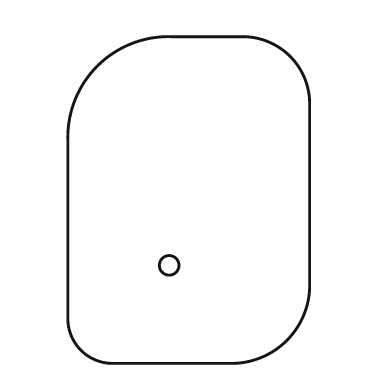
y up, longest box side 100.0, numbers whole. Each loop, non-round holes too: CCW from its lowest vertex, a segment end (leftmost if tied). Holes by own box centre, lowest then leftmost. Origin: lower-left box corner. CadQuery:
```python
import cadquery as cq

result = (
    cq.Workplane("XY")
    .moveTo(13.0, 0.0)
    .lineTo(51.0, 0.0)
    .threePointArc((67.0, 7.0), (74.0, 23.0))
    .lineTo(74.0, 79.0)
    .threePointArc((68.0, 94.0), (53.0, 100.0))
    .lineTo(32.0, 100.0)
    .threePointArc((9.0, 91.0), (0.0, 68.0))
    .lineTo(0.0, 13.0)
    .threePointArc((4.0, 4.0), (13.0, 0.0))
    .close()
    .moveTo(31.0, 30.0)
    .circle(3.0)
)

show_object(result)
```